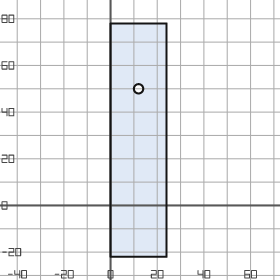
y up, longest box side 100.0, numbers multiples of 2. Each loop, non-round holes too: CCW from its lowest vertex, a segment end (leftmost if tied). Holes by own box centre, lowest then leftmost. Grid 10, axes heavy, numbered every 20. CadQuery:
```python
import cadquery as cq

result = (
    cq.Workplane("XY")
    .moveTo(0.0, -22.0)
    .lineTo(24.0, -22.0)
    .lineTo(24.0, 78.0)
    .lineTo(0.0, 78.0)
    .close()
    .moveTo(12.0, 50.0)
    .circle(2.0)
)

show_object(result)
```